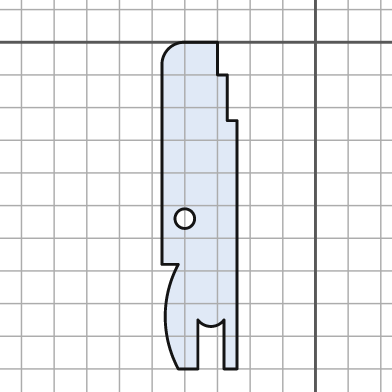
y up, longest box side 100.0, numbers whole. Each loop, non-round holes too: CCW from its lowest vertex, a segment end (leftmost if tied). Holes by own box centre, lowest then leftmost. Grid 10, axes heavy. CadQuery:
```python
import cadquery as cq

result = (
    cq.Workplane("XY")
    .moveTo(-42.0, -100.0)
    .lineTo(-36.0, -100.0)
    .lineTo(-36.0, -85.0)
    .threePointArc((-32.0, -87.0), (-28.0, -85.0))
    .lineTo(-28.0, -100.0)
    .lineTo(-24.0, -100.0)
    .lineTo(-24.0, -24.0)
    .lineTo(-27.0, -24.0)
    .lineTo(-27.0, -10.0)
    .lineTo(-30.0, -10.0)
    .lineTo(-30.0, 0.0)
    .lineTo(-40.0, 0.0)
    .threePointArc((-45.0, -2.0), (-47.0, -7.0))
    .lineTo(-47.0, -68.0)
    .lineTo(-42.0, -68.0)
    .threePointArc((-46.0, -84.0), (-42.0, -100.0))
    .close()
    .moveTo(-40.0, -54.0)
    .circle(3.0)
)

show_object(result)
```